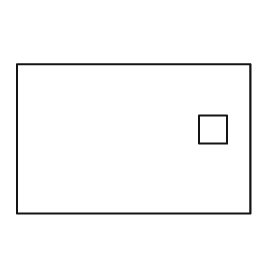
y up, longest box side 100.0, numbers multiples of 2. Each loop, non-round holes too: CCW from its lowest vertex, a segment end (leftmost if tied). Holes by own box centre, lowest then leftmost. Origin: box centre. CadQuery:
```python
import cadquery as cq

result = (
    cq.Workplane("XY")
    .moveTo(-50.0, -32.0)
    .lineTo(50.0, -32.0)
    .lineTo(50.0, 32.0)
    .lineTo(-50.0, 32.0)
    .close()
    .moveTo(28.0, -2.0)
    .lineTo(40.0, -2.0)
    .lineTo(40.0, 10.0)
    .lineTo(28.0, 10.0)
    .close()
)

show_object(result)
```